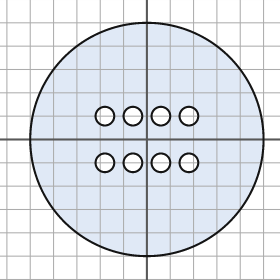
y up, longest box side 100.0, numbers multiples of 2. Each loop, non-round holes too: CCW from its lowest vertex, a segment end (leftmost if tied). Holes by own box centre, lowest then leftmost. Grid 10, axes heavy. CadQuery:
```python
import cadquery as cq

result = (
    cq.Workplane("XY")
    .moveTo(0.0, 0.0)
    .circle(50.0)
    .moveTo(-18.0, -10.0)
    .circle(4.0)
    .moveTo(-6.0, -10.0)
    .circle(4.0)
    .moveTo(6.0, -10.0)
    .circle(4.0)
    .moveTo(18.0, -10.0)
    .circle(4.0)
    .moveTo(-18.0, 10.0)
    .circle(4.0)
    .moveTo(-6.0, 10.0)
    .circle(4.0)
    .moveTo(6.0, 10.0)
    .circle(4.0)
    .moveTo(18.0, 10.0)
    .circle(4.0)
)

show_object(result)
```